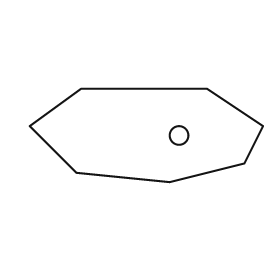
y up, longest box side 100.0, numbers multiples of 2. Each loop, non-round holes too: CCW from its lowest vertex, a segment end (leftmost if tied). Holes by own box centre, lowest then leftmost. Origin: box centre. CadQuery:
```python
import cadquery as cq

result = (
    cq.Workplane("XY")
    .moveTo(10.0, -20.0)
    .lineTo(42.0, -12.0)
    .lineTo(50.0, 4.0)
    .lineTo(26.0, 20.0)
    .lineTo(-28.0, 20.0)
    .lineTo(-50.0, 4.0)
    .lineTo(-30.0, -16.0)
    .close()
    .moveTo(14.0, 0.0)
    .circle(4.0)
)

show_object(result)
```